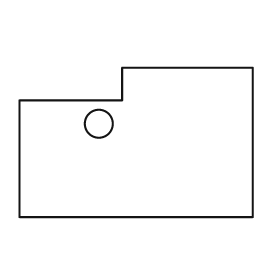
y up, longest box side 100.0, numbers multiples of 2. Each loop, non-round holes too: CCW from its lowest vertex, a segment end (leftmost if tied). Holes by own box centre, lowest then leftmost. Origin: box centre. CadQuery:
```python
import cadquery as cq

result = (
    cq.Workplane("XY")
    .moveTo(-50.0, -32.0)
    .lineTo(50.0, -32.0)
    .lineTo(50.0, 32.0)
    .lineTo(-6.0, 32.0)
    .lineTo(-6.0, 18.0)
    .lineTo(-50.0, 18.0)
    .close()
    .moveTo(-16.0, 8.0)
    .circle(6.0)
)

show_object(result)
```